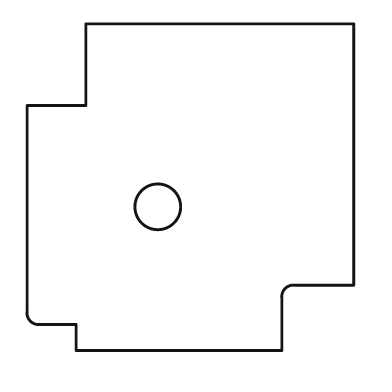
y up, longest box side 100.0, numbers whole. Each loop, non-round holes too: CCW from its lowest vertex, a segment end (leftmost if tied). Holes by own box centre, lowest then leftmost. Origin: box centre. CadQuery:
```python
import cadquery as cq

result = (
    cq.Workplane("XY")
    .moveTo(-35.0, -50.0)
    .lineTo(28.0, -50.0)
    .lineTo(28.0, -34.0)
    .threePointArc((29.0, -31.0), (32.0, -30.0))
    .lineTo(50.0, -30.0)
    .lineTo(50.0, 50.0)
    .lineTo(-32.0, 50.0)
    .lineTo(-32.0, 25.0)
    .lineTo(-50.0, 25.0)
    .lineTo(-50.0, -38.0)
    .threePointArc((-49.0, -41.0), (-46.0, -42.0))
    .lineTo(-35.0, -42.0)
    .close()
    .moveTo(-10.0, -6.0)
    .circle(7.0)
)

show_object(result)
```